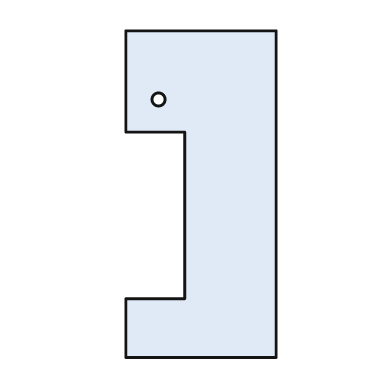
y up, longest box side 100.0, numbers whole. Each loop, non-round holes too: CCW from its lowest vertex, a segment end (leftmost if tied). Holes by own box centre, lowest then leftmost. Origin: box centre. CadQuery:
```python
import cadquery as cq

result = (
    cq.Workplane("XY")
    .moveTo(-23.0, -50.0)
    .lineTo(23.0, -50.0)
    .lineTo(23.0, 50.0)
    .lineTo(-23.0, 50.0)
    .lineTo(-23.0, 19.0)
    .lineTo(-5.0, 19.0)
    .lineTo(-5.0, -32.0)
    .lineTo(-23.0, -32.0)
    .close()
    .moveTo(-13.0, 29.0)
    .circle(2.0)
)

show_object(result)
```